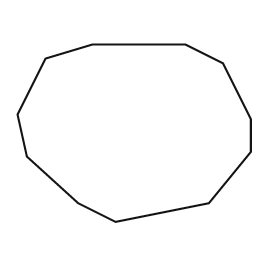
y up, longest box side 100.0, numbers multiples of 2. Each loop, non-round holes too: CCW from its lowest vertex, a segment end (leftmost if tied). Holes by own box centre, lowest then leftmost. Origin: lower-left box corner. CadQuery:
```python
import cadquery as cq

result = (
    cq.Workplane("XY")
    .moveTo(42.0, 0.0)
    .lineTo(82.0, 8.0)
    .lineTo(100.0, 30.0)
    .lineTo(100.0, 44.0)
    .lineTo(88.0, 68.0)
    .lineTo(72.0, 76.0)
    .lineTo(32.0, 76.0)
    .lineTo(12.0, 70.0)
    .lineTo(0.0, 46.0)
    .lineTo(4.0, 28.0)
    .lineTo(26.0, 8.0)
    .close()
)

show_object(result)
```